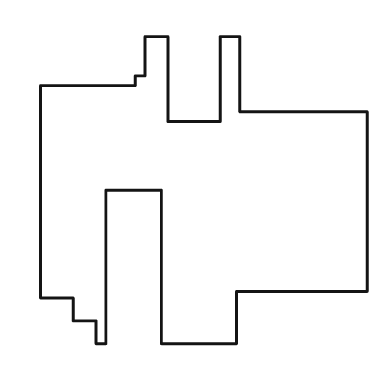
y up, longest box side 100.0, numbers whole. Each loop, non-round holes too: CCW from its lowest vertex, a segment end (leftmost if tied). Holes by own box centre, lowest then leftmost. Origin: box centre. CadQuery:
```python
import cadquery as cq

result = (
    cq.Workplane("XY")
    .moveTo(-33.0, -47.0)
    .lineTo(-30.0, -47.0)
    .lineTo(-30.0, 0.0)
    .lineTo(-13.0, 0.0)
    .lineTo(-13.0, -47.0)
    .lineTo(10.0, -47.0)
    .lineTo(10.0, -31.0)
    .lineTo(50.0, -31.0)
    .lineTo(50.0, 24.0)
    .lineTo(11.0, 24.0)
    .lineTo(11.0, 47.0)
    .lineTo(5.0, 47.0)
    .lineTo(5.0, 21.0)
    .lineTo(-11.0, 21.0)
    .lineTo(-11.0, 47.0)
    .lineTo(-18.0, 47.0)
    .lineTo(-18.0, 35.0)
    .lineTo(-21.0, 35.0)
    .lineTo(-21.0, 32.0)
    .lineTo(-50.0, 32.0)
    .lineTo(-50.0, -33.0)
    .lineTo(-40.0, -33.0)
    .lineTo(-40.0, -40.0)
    .lineTo(-33.0, -40.0)
    .close()
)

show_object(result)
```